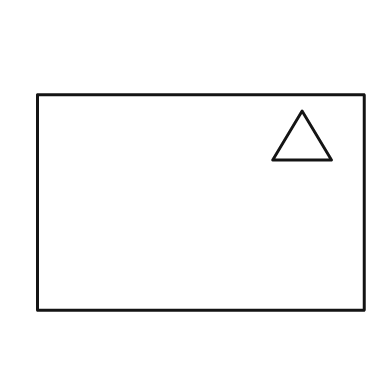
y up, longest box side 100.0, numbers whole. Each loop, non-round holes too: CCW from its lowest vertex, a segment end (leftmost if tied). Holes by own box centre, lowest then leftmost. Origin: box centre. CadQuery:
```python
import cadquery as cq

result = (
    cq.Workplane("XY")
    .moveTo(-50.0, -33.0)
    .lineTo(50.0, -33.0)
    .lineTo(50.0, 33.0)
    .lineTo(-50.0, 33.0)
    .close()
    .moveTo(22.0, 13.0)
    .lineTo(40.0, 13.0)
    .lineTo(31.0, 28.0)
    .close()
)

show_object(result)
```